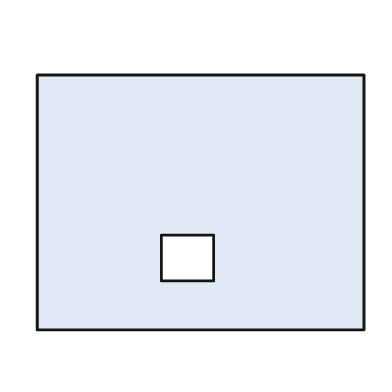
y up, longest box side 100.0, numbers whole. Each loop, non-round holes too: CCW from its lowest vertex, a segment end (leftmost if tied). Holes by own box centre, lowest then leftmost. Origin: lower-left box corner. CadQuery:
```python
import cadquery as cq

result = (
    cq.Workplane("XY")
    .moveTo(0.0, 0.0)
    .lineTo(100.0, 0.0)
    .lineTo(100.0, 78.0)
    .lineTo(0.0, 78.0)
    .close()
    .moveTo(38.0, 15.0)
    .lineTo(54.0, 15.0)
    .lineTo(54.0, 29.0)
    .lineTo(38.0, 29.0)
    .close()
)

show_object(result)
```